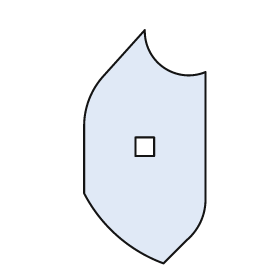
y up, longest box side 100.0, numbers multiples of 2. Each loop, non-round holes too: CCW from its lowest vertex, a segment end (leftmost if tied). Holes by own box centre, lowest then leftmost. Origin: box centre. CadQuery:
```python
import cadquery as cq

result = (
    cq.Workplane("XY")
    .moveTo(8.0, -50.0)
    .lineTo(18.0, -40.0)
    .threePointArc((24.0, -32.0), (26.0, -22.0))
    .lineTo(26.0, 32.0)
    .threePointArc((8.0, 34.0), (0.0, 50.0))
    .lineTo(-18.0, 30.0)
    .threePointArc((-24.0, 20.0), (-26.0, 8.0))
    .lineTo(-26.0, -20.0)
    .threePointArc((-12.0, -38.0), (8.0, -50.0))
    .close()
    .moveTo(-4.0, -4.0)
    .lineTo(4.0, -4.0)
    .lineTo(4.0, 4.0)
    .lineTo(-4.0, 4.0)
    .close()
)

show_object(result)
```